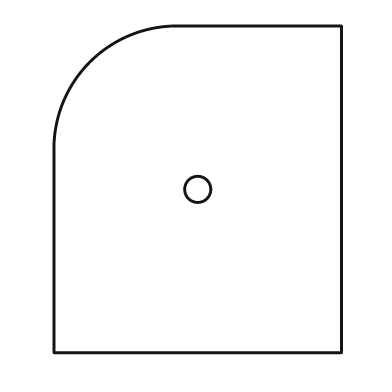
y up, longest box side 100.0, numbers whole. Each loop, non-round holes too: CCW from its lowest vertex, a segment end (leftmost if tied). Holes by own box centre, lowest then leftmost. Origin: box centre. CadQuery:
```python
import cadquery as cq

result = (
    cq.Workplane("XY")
    .moveTo(-44.0, -50.0)
    .lineTo(44.0, -50.0)
    .lineTo(44.0, 50.0)
    .lineTo(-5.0, 50.0)
    .threePointArc((-33.0, 39.0), (-44.0, 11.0))
    .close()
    .moveTo(0.0, 0.0)
    .circle(4.0)
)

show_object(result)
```